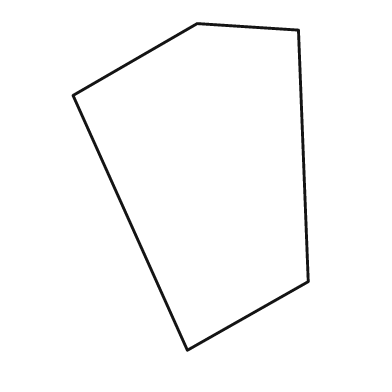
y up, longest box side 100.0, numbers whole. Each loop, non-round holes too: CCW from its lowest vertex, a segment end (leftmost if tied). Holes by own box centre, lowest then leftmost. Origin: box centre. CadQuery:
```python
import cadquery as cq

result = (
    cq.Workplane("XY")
    .moveTo(-1.0, -50.0)
    .lineTo(36.0, -29.0)
    .lineTo(33.0, 48.0)
    .lineTo(2.0, 50.0)
    .lineTo(-36.0, 28.0)
    .close()
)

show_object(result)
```